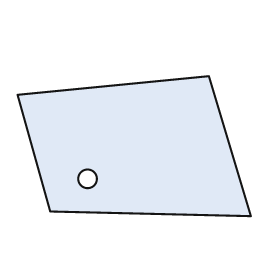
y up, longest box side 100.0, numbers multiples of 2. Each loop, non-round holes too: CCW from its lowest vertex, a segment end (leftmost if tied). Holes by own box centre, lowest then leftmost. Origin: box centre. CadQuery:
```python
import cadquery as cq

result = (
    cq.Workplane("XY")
    .moveTo(50.0, -30.0)
    .lineTo(32.0, 30.0)
    .lineTo(-50.0, 22.0)
    .lineTo(-36.0, -28.0)
    .close()
    .moveTo(-20.0, -14.0)
    .circle(4.0)
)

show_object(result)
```